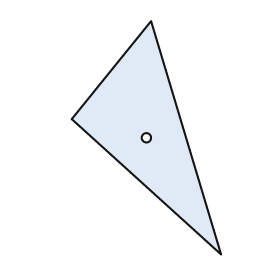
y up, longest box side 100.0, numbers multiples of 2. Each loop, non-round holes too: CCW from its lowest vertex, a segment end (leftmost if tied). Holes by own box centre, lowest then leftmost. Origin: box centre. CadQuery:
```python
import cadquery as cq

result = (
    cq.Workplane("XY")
    .moveTo(32.0, -50.0)
    .lineTo(2.0, 50.0)
    .lineTo(-32.0, 8.0)
    .close()
    .moveTo(0.0, 0.0)
    .circle(2.0)
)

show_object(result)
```